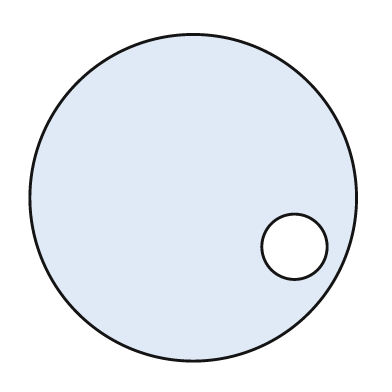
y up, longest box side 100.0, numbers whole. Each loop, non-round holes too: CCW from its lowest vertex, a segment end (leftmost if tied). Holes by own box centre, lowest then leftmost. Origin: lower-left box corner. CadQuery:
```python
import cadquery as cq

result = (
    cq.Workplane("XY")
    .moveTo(50.0, 50.0)
    .circle(50.0)
    .moveTo(81.0, 35.0)
    .circle(10.0)
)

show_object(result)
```